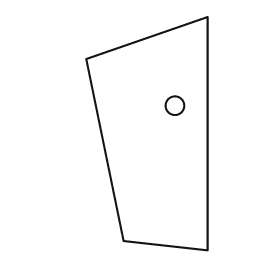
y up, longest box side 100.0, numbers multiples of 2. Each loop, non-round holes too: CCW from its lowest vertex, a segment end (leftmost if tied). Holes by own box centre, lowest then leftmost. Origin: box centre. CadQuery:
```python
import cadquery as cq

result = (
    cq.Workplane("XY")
    .moveTo(26.0, -50.0)
    .lineTo(26.0, 50.0)
    .lineTo(-26.0, 32.0)
    .lineTo(-10.0, -46.0)
    .close()
    .moveTo(12.0, 12.0)
    .circle(4.0)
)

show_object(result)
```